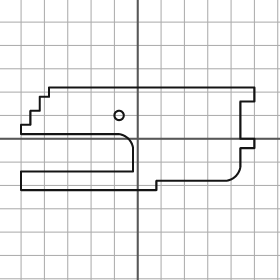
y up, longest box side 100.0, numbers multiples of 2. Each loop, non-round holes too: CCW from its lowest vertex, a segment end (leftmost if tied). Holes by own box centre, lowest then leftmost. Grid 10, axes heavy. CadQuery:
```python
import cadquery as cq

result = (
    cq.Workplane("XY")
    .moveTo(-50.0, -22.0)
    .lineTo(8.0, -22.0)
    .lineTo(8.0, -18.0)
    .lineTo(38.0, -18.0)
    .threePointArc((42.0, -16.0), (44.0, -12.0))
    .lineTo(44.0, -4.0)
    .lineTo(50.0, -4.0)
    .lineTo(50.0, 0.0)
    .lineTo(44.0, 0.0)
    .lineTo(44.0, 16.0)
    .lineTo(50.0, 16.0)
    .lineTo(50.0, 22.0)
    .lineTo(-38.0, 22.0)
    .lineTo(-38.0, 18.0)
    .lineTo(-42.0, 18.0)
    .lineTo(-42.0, 12.0)
    .lineTo(-46.0, 12.0)
    .lineTo(-46.0, 6.0)
    .lineTo(-50.0, 6.0)
    .lineTo(-50.0, 2.0)
    .lineTo(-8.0, 2.0)
    .threePointArc((-4.0, 0.0), (-2.0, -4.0))
    .lineTo(-2.0, -14.0)
    .lineTo(-50.0, -14.0)
    .close()
    .moveTo(-8.0, 10.0)
    .circle(2.0)
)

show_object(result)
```